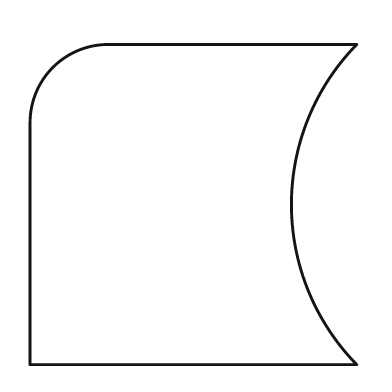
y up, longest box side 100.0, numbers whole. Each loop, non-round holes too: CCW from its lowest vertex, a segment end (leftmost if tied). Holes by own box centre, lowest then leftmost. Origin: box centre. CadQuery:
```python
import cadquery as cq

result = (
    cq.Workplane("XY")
    .moveTo(-50.0, -49.0)
    .lineTo(50.0, -49.0)
    .threePointArc((30.0, 0.0), (50.0, 49.0))
    .lineTo(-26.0, 49.0)
    .threePointArc((-43.0, 42.0), (-50.0, 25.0))
    .close()
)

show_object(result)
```